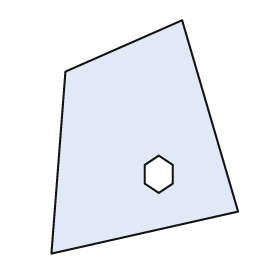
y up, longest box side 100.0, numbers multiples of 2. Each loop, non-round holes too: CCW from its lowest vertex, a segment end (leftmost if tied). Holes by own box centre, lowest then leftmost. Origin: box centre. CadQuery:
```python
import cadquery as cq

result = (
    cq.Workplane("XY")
    .moveTo(-40.0, -50.0)
    .lineTo(40.0, -32.0)
    .lineTo(16.0, 50.0)
    .lineTo(-34.0, 28.0)
    .close()
    .moveTo(6.0, -24.0)
    .lineTo(12.0, -20.0)
    .lineTo(12.0, -12.0)
    .lineTo(6.0, -8.0)
    .lineTo(0.0, -12.0)
    .lineTo(0.0, -20.0)
    .close()
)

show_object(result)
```